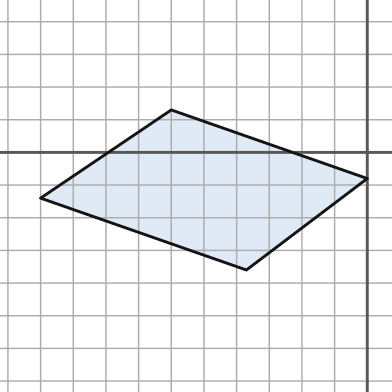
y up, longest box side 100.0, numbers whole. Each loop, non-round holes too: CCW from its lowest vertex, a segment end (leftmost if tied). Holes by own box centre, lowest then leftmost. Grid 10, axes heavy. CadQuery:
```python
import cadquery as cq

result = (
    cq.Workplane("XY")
    .moveTo(-37.0, -36.0)
    .lineTo(0.0, -8.0)
    .lineTo(-60.0, 13.0)
    .lineTo(-100.0, -14.0)
    .close()
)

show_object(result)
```